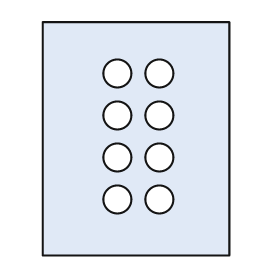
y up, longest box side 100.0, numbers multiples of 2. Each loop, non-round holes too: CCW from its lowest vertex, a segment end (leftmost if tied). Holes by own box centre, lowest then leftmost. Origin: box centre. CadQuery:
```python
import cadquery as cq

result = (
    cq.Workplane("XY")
    .moveTo(-40.0, -50.0)
    .lineTo(40.0, -50.0)
    .lineTo(40.0, 50.0)
    .lineTo(-40.0, 50.0)
    .close()
    .moveTo(-8.0, -26.0)
    .circle(6.0)
    .moveTo(10.0, -26.0)
    .circle(6.0)
    .moveTo(-8.0, -8.0)
    .circle(6.0)
    .moveTo(10.0, -8.0)
    .circle(6.0)
    .moveTo(-8.0, 10.0)
    .circle(6.0)
    .moveTo(10.0, 10.0)
    .circle(6.0)
    .moveTo(-8.0, 28.0)
    .circle(6.0)
    .moveTo(10.0, 28.0)
    .circle(6.0)
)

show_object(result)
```